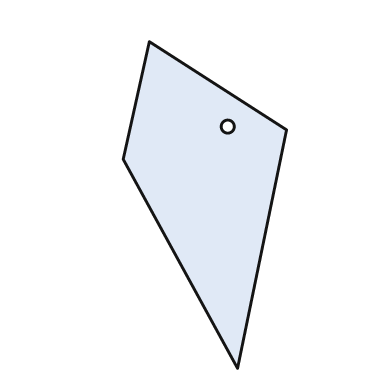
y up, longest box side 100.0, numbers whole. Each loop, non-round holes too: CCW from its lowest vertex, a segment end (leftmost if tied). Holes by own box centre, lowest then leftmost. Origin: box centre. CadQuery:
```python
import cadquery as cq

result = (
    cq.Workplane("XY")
    .moveTo(10.0, -50.0)
    .lineTo(25.0, 23.0)
    .lineTo(-17.0, 50.0)
    .lineTo(-25.0, 14.0)
    .close()
    .moveTo(7.0, 24.0)
    .circle(2.0)
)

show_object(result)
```